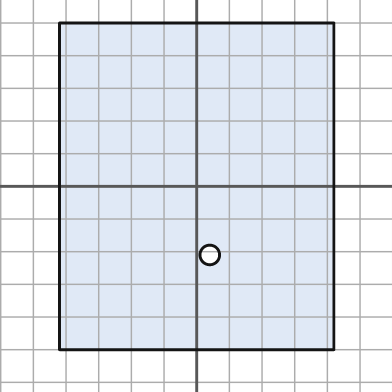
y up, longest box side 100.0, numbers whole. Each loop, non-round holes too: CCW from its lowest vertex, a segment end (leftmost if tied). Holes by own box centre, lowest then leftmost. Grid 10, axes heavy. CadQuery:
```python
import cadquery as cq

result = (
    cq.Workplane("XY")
    .moveTo(-42.0, -50.0)
    .lineTo(42.0, -50.0)
    .lineTo(42.0, 50.0)
    .lineTo(-42.0, 50.0)
    .close()
    .moveTo(4.0, -21.0)
    .circle(3.0)
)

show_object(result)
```